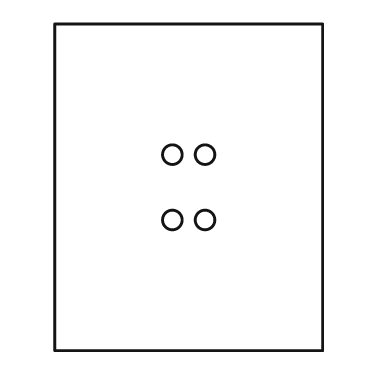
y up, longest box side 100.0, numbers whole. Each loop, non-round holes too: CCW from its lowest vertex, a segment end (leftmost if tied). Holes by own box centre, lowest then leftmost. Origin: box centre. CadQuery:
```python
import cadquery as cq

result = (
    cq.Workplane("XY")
    .moveTo(-41.0, -50.0)
    .lineTo(41.0, -50.0)
    .lineTo(41.0, 50.0)
    .lineTo(-41.0, 50.0)
    .close()
    .moveTo(-5.0, -10.0)
    .circle(3.0)
    .moveTo(5.0, -10.0)
    .circle(3.0)
    .moveTo(-5.0, 10.0)
    .circle(3.0)
    .moveTo(5.0, 10.0)
    .circle(3.0)
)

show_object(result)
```